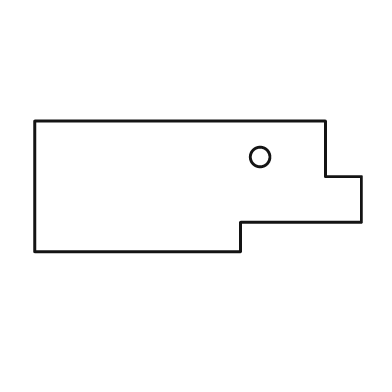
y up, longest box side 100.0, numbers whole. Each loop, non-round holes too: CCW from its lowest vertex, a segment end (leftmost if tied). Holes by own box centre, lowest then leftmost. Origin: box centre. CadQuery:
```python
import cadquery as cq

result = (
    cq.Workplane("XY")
    .moveTo(-50.0, -20.0)
    .lineTo(13.0, -20.0)
    .lineTo(13.0, -11.0)
    .lineTo(50.0, -11.0)
    .lineTo(50.0, 3.0)
    .lineTo(39.0, 3.0)
    .lineTo(39.0, 20.0)
    .lineTo(-50.0, 20.0)
    .close()
    .moveTo(19.0, 9.0)
    .circle(3.0)
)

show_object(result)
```